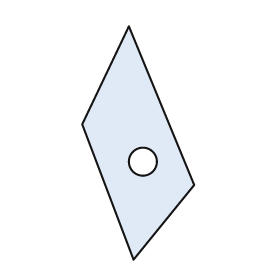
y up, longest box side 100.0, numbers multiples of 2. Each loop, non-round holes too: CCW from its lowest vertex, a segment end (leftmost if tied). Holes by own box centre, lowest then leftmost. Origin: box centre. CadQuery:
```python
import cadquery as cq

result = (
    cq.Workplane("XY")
    .moveTo(-2.0, -50.0)
    .lineTo(24.0, -18.0)
    .lineTo(-4.0, 50.0)
    .lineTo(-24.0, 8.0)
    .close()
    .moveTo(2.0, -8.0)
    .circle(6.0)
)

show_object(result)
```